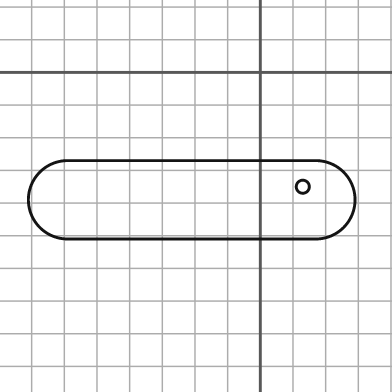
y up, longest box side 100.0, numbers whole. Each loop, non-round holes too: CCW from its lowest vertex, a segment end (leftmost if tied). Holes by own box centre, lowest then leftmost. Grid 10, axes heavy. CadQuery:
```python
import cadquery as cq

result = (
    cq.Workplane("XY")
    .moveTo(-59.0, -51.0)
    .lineTo(17.0, -51.0)
    .threePointArc((29.0, -39.0), (17.0, -27.0))
    .lineTo(-59.0, -27.0)
    .threePointArc((-71.0, -39.0), (-59.0, -51.0))
    .close()
    .moveTo(13.0, -35.0)
    .circle(2.0)
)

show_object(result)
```